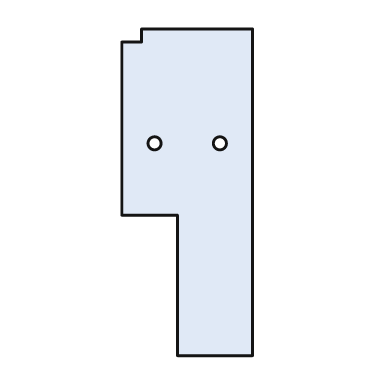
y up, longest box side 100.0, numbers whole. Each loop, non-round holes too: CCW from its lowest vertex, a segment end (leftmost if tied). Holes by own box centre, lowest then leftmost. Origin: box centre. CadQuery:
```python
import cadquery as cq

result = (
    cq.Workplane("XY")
    .moveTo(-3.0, -50.0)
    .lineTo(20.0, -50.0)
    .lineTo(20.0, 50.0)
    .lineTo(-14.0, 50.0)
    .lineTo(-14.0, 46.0)
    .lineTo(-20.0, 46.0)
    .lineTo(-20.0, -7.0)
    .lineTo(-3.0, -7.0)
    .close()
    .moveTo(-10.0, 15.0)
    .circle(2.0)
    .moveTo(10.0, 15.0)
    .circle(2.0)
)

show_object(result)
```